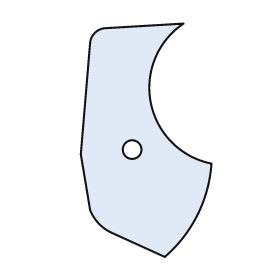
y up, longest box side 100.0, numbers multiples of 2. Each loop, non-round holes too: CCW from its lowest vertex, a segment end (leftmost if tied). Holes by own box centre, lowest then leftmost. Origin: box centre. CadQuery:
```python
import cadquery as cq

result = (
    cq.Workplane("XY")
    .moveTo(8.0, -50.0)
    .threePointArc((22.0, -32.0), (28.0, -10.0))
    .threePointArc((2.0, 16.0), (16.0, 50.0))
    .lineTo(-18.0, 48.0)
    .threePointArc((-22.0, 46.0), (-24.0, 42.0))
    .lineTo(-28.0, -6.0)
    .lineTo(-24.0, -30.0)
    .threePointArc((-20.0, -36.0), (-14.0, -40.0))
    .close()
    .moveTo(-6.0, -4.0)
    .circle(4.0)
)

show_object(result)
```